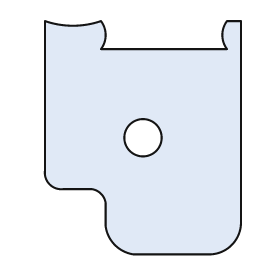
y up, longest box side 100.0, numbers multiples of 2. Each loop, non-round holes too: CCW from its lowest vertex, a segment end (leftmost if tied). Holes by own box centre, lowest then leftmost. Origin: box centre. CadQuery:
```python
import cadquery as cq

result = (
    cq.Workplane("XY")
    .moveTo(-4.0, -50.0)
    .lineTo(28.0, -50.0)
    .threePointArc((38.0, -46.0), (42.0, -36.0))
    .lineTo(42.0, 50.0)
    .lineTo(36.0, 50.0)
    .threePointArc((34.0, 44.0), (36.0, 38.0))
    .lineTo(-18.0, 38.0)
    .threePointArc((-16.0, 44.0), (-18.0, 50.0))
    .threePointArc((-30.0, 48.0), (-42.0, 50.0))
    .lineTo(-42.0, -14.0)
    .threePointArc((-40.0, -20.0), (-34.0, -22.0))
    .lineTo(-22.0, -22.0)
    .threePointArc((-18.0, -24.0), (-16.0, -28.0))
    .lineTo(-16.0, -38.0)
    .threePointArc((-12.0, -46.0), (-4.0, -50.0))
    .close()
    .moveTo(0.0, 0.0)
    .circle(8.0)
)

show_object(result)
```